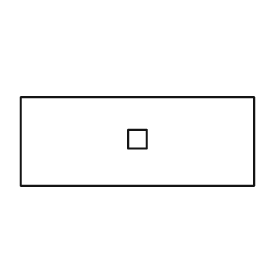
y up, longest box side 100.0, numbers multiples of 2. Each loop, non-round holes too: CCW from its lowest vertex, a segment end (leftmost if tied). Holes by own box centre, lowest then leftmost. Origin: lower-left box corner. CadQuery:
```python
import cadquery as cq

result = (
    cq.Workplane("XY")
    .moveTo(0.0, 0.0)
    .lineTo(100.0, 0.0)
    .lineTo(100.0, 38.0)
    .lineTo(0.0, 38.0)
    .close()
    .moveTo(46.0, 16.0)
    .lineTo(54.0, 16.0)
    .lineTo(54.0, 24.0)
    .lineTo(46.0, 24.0)
    .close()
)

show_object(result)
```